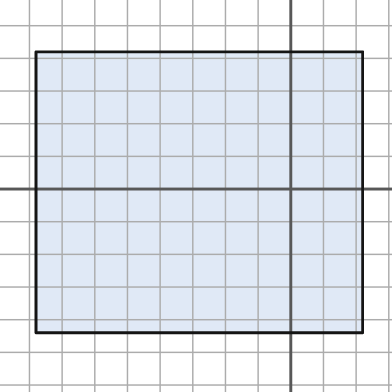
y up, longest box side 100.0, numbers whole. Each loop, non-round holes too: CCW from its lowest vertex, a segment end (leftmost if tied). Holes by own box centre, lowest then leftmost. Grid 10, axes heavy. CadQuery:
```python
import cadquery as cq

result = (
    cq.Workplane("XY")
    .moveTo(-78.0, -44.0)
    .lineTo(22.0, -44.0)
    .lineTo(22.0, 42.0)
    .lineTo(-78.0, 42.0)
    .close()
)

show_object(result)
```